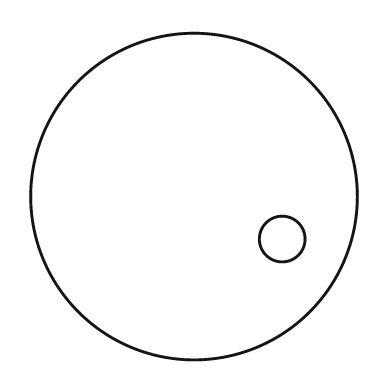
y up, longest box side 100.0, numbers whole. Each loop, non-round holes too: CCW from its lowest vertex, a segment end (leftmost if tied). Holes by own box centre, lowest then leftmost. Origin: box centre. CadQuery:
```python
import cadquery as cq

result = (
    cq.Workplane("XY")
    .moveTo(0.0, 0.0)
    .circle(50.0)
    .moveTo(27.0, -13.0)
    .circle(7.0)
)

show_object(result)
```